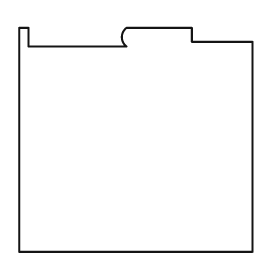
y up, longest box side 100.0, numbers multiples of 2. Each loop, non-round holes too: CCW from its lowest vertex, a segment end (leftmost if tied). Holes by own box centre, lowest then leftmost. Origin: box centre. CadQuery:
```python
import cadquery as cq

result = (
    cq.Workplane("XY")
    .moveTo(-50.0, -48.0)
    .lineTo(50.0, -48.0)
    .lineTo(50.0, 42.0)
    .lineTo(24.0, 42.0)
    .lineTo(24.0, 48.0)
    .lineTo(-4.0, 48.0)
    .threePointArc((-6.0, 44.0), (-4.0, 40.0))
    .lineTo(-46.0, 40.0)
    .lineTo(-46.0, 48.0)
    .lineTo(-50.0, 48.0)
    .close()
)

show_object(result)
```